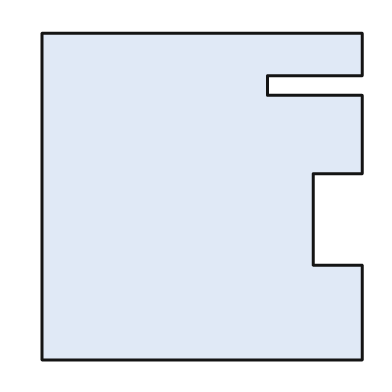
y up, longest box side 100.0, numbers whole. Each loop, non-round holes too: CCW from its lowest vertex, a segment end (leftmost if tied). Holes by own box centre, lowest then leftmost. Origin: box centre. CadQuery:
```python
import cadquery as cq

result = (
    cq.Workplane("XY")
    .moveTo(-49.0, -50.0)
    .lineTo(49.0, -50.0)
    .lineTo(49.0, -21.0)
    .lineTo(34.0, -21.0)
    .lineTo(34.0, 7.0)
    .lineTo(49.0, 7.0)
    .lineTo(49.0, 31.0)
    .lineTo(20.0, 31.0)
    .lineTo(20.0, 37.0)
    .lineTo(49.0, 37.0)
    .lineTo(49.0, 50.0)
    .lineTo(-49.0, 50.0)
    .close()
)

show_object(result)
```